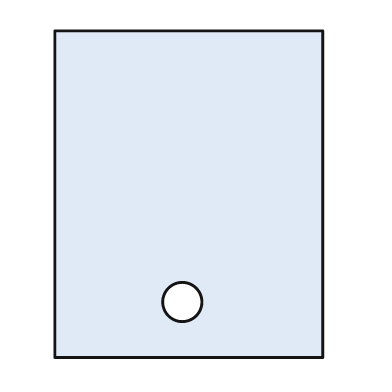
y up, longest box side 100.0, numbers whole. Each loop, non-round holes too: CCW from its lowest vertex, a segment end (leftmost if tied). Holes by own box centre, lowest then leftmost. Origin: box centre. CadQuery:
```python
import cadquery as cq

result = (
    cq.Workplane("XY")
    .moveTo(-41.0, -50.0)
    .lineTo(41.0, -50.0)
    .lineTo(41.0, 50.0)
    .lineTo(-41.0, 50.0)
    .close()
    .moveTo(-2.0, -33.0)
    .circle(6.0)
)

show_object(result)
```